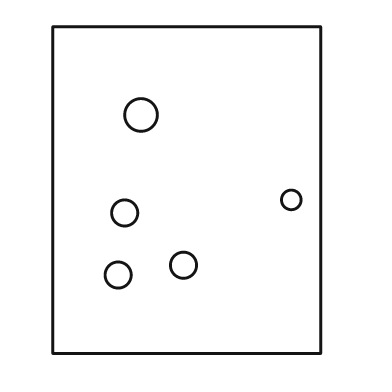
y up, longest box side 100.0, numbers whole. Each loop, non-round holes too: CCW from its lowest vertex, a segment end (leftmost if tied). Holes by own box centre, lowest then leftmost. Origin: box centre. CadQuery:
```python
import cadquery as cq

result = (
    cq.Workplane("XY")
    .moveTo(-41.0, -50.0)
    .lineTo(41.0, -50.0)
    .lineTo(41.0, 50.0)
    .lineTo(-41.0, 50.0)
    .close()
    .moveTo(-21.0, -26.0)
    .circle(4.0)
    .moveTo(-1.0, -23.0)
    .circle(4.0)
    .moveTo(-19.0, -7.0)
    .circle(4.0)
    .moveTo(32.0, -3.0)
    .circle(3.0)
    .moveTo(-14.0, 23.0)
    .circle(5.0)
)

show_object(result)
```